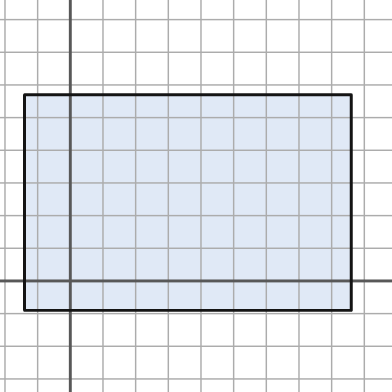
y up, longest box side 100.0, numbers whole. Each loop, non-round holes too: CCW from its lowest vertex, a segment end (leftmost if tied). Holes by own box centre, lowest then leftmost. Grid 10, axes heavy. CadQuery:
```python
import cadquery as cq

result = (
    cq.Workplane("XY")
    .moveTo(-14.0, -9.0)
    .lineTo(86.0, -9.0)
    .lineTo(86.0, 57.0)
    .lineTo(-14.0, 57.0)
    .close()
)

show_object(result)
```